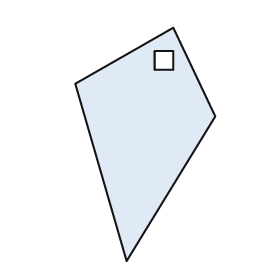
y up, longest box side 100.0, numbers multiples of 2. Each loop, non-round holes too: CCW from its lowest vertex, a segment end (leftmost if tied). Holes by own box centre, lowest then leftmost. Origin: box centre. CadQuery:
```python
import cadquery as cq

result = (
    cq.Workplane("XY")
    .moveTo(-8.0, -50.0)
    .lineTo(30.0, 12.0)
    .lineTo(12.0, 50.0)
    .lineTo(-30.0, 26.0)
    .close()
    .moveTo(4.0, 32.0)
    .lineTo(12.0, 32.0)
    .lineTo(12.0, 40.0)
    .lineTo(4.0, 40.0)
    .close()
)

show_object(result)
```